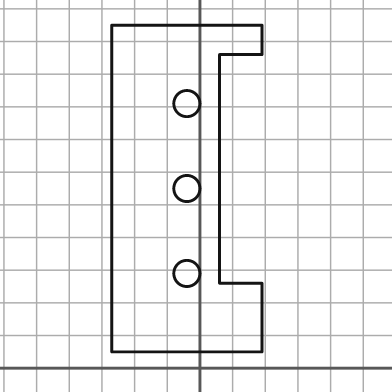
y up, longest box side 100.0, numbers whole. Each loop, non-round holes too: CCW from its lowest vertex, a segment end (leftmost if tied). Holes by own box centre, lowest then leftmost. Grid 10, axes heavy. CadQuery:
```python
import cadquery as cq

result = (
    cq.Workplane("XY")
    .moveTo(-27.0, 5.0)
    .lineTo(19.0, 5.0)
    .lineTo(19.0, 26.0)
    .lineTo(6.0, 26.0)
    .lineTo(6.0, 96.0)
    .lineTo(19.0, 96.0)
    .lineTo(19.0, 105.0)
    .lineTo(-27.0, 105.0)
    .close()
    .moveTo(-4.0, 29.0)
    .circle(4.0)
    .moveTo(-4.0, 55.0)
    .circle(4.0)
    .moveTo(-4.0, 81.0)
    .circle(4.0)
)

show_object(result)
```